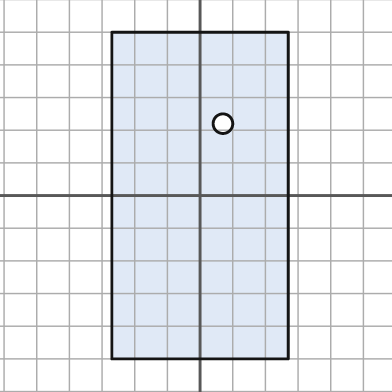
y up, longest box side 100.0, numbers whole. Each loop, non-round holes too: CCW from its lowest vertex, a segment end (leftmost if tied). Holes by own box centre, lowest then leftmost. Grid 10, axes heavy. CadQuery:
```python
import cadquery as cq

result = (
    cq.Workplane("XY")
    .moveTo(-27.0, -50.0)
    .lineTo(27.0, -50.0)
    .lineTo(27.0, 50.0)
    .lineTo(-27.0, 50.0)
    .close()
    .moveTo(7.0, 22.0)
    .circle(3.0)
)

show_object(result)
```